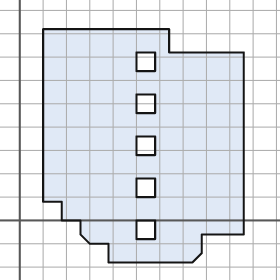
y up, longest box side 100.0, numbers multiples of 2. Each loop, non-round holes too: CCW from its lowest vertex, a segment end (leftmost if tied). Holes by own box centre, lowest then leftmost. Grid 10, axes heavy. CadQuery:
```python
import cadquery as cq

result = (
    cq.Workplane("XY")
    .moveTo(38.0, -18.0)
    .lineTo(74.0, -18.0)
    .lineTo(78.0, -14.0)
    .lineTo(78.0, -6.0)
    .lineTo(96.0, -6.0)
    .lineTo(96.0, 72.0)
    .lineTo(64.0, 72.0)
    .lineTo(64.0, 82.0)
    .lineTo(10.0, 82.0)
    .lineTo(10.0, 8.0)
    .lineTo(18.0, 8.0)
    .lineTo(18.0, 0.0)
    .lineTo(26.0, 0.0)
    .lineTo(26.0, -6.0)
    .lineTo(30.0, -10.0)
    .lineTo(38.0, -10.0)
    .close()
    .moveTo(50.0, -8.0)
    .lineTo(58.0, -8.0)
    .lineTo(58.0, 0.0)
    .lineTo(50.0, 0.0)
    .close()
    .moveTo(50.0, 10.0)
    .lineTo(58.0, 10.0)
    .lineTo(58.0, 18.0)
    .lineTo(50.0, 18.0)
    .close()
    .moveTo(50.0, 28.0)
    .lineTo(58.0, 28.0)
    .lineTo(58.0, 36.0)
    .lineTo(50.0, 36.0)
    .close()
    .moveTo(50.0, 46.0)
    .lineTo(58.0, 46.0)
    .lineTo(58.0, 54.0)
    .lineTo(50.0, 54.0)
    .close()
    .moveTo(50.0, 64.0)
    .lineTo(58.0, 64.0)
    .lineTo(58.0, 72.0)
    .lineTo(50.0, 72.0)
    .close()
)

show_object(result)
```